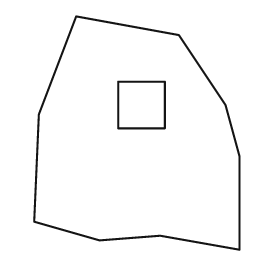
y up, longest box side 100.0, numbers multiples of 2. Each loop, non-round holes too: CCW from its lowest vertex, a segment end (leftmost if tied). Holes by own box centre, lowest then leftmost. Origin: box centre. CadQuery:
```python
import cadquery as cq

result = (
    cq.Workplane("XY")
    .moveTo(44.0, -50.0)
    .lineTo(44.0, -10.0)
    .lineTo(38.0, 12.0)
    .lineTo(18.0, 42.0)
    .lineTo(-26.0, 50.0)
    .lineTo(-42.0, 8.0)
    .lineTo(-44.0, -38.0)
    .lineTo(-16.0, -46.0)
    .lineTo(10.0, -44.0)
    .close()
    .moveTo(-8.0, 2.0)
    .lineTo(12.0, 2.0)
    .lineTo(12.0, 22.0)
    .lineTo(-8.0, 22.0)
    .close()
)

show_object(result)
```